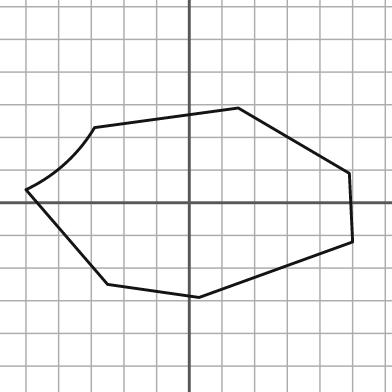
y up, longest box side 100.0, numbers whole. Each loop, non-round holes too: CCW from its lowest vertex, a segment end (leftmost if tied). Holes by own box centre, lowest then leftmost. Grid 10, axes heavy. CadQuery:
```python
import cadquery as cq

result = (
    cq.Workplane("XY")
    .moveTo(3.0, -29.0)
    .lineTo(50.0, -12.0)
    .lineTo(49.0, 9.0)
    .lineTo(15.0, 29.0)
    .lineTo(-29.0, 23.0)
    .threePointArc((-38.0, 12.0), (-50.0, 4.0))
    .lineTo(-25.0, -25.0)
    .close()
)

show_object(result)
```